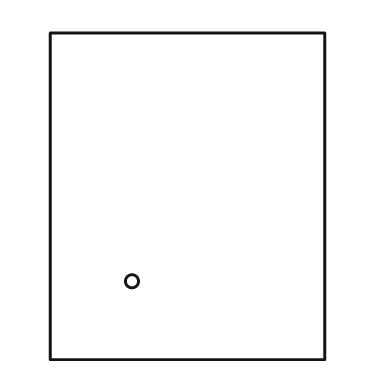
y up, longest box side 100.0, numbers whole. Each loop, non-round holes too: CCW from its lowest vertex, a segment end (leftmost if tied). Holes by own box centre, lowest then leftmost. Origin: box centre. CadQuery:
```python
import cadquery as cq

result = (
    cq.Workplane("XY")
    .moveTo(-42.0, -50.0)
    .lineTo(42.0, -50.0)
    .lineTo(42.0, 50.0)
    .lineTo(-42.0, 50.0)
    .close()
    .moveTo(-17.0, -26.0)
    .circle(2.0)
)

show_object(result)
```